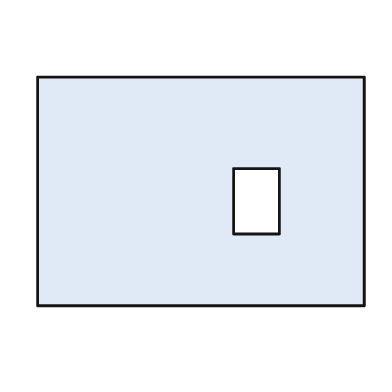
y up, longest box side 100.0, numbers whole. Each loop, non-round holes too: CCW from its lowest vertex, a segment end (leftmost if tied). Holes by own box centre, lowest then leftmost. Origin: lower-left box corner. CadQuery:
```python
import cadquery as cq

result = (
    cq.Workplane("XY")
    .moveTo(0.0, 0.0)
    .lineTo(100.0, 0.0)
    .lineTo(100.0, 70.0)
    .lineTo(0.0, 70.0)
    .close()
    .moveTo(60.0, 22.0)
    .lineTo(74.0, 22.0)
    .lineTo(74.0, 42.0)
    .lineTo(60.0, 42.0)
    .close()
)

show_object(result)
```